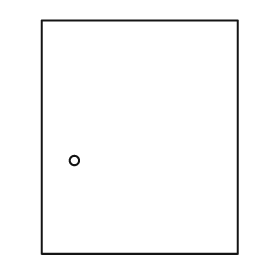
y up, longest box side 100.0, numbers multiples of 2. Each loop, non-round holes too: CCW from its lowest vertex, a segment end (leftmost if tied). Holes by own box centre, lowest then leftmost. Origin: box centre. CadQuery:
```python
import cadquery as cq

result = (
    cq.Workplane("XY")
    .moveTo(-42.0, -50.0)
    .lineTo(42.0, -50.0)
    .lineTo(42.0, 50.0)
    .lineTo(-42.0, 50.0)
    .close()
    .moveTo(-28.0, -10.0)
    .circle(2.0)
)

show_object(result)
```